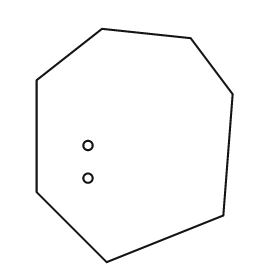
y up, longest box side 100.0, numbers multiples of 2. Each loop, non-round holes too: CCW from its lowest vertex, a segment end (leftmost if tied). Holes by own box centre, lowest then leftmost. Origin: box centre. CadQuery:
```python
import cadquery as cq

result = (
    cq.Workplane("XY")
    .moveTo(-12.0, -50.0)
    .lineTo(38.0, -30.0)
    .lineTo(42.0, 22.0)
    .lineTo(24.0, 46.0)
    .lineTo(-14.0, 50.0)
    .lineTo(-42.0, 28.0)
    .lineTo(-42.0, -20.0)
    .close()
    .moveTo(-20.0, -14.0)
    .circle(2.0)
    .moveTo(-20.0, 0.0)
    .circle(2.0)
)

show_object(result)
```